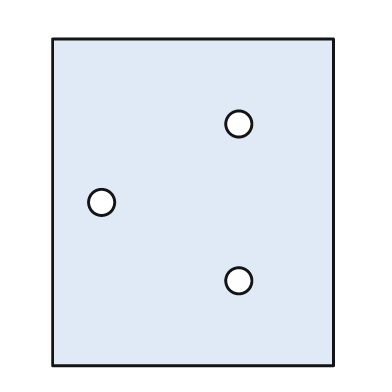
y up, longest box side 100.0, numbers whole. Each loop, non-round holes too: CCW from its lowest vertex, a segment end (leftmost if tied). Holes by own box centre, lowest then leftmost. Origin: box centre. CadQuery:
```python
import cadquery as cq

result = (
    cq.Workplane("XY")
    .moveTo(-43.0, -50.0)
    .lineTo(43.0, -50.0)
    .lineTo(43.0, 50.0)
    .lineTo(-43.0, 50.0)
    .close()
    .moveTo(14.0, -24.0)
    .circle(4.0)
    .moveTo(-28.0, 0.0)
    .circle(4.0)
    .moveTo(14.0, 24.0)
    .circle(4.0)
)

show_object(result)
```